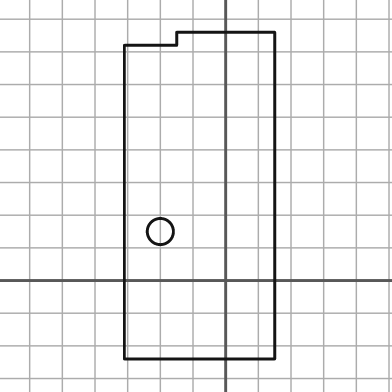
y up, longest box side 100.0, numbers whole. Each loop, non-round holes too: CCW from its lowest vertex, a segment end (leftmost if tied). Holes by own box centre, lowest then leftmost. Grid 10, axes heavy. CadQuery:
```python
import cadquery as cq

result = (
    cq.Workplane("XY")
    .moveTo(-31.0, -24.0)
    .lineTo(15.0, -24.0)
    .lineTo(15.0, 76.0)
    .lineTo(-15.0, 76.0)
    .lineTo(-15.0, 72.0)
    .lineTo(-31.0, 72.0)
    .close()
    .moveTo(-20.0, 15.0)
    .circle(4.0)
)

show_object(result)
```